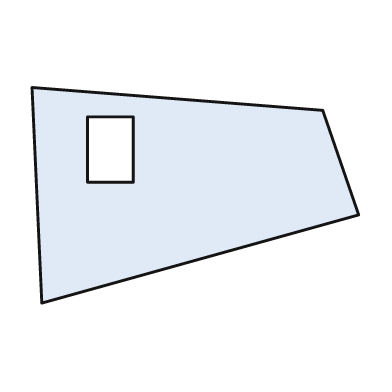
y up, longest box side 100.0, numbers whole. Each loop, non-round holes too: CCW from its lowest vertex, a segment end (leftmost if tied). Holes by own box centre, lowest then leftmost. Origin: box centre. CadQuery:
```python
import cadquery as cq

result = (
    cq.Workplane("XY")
    .moveTo(-47.0, -33.0)
    .lineTo(50.0, -6.0)
    .lineTo(39.0, 26.0)
    .lineTo(-50.0, 33.0)
    .close()
    .moveTo(-33.0, 4.0)
    .lineTo(-19.0, 4.0)
    .lineTo(-19.0, 24.0)
    .lineTo(-33.0, 24.0)
    .close()
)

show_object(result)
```